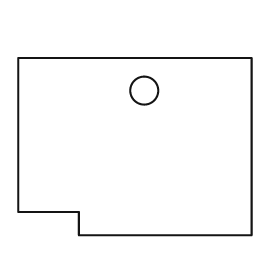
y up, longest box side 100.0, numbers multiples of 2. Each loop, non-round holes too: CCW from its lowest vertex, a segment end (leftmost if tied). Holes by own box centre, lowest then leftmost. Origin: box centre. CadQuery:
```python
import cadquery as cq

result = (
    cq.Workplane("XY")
    .moveTo(-24.0, -38.0)
    .lineTo(50.0, -38.0)
    .lineTo(50.0, 38.0)
    .lineTo(-50.0, 38.0)
    .lineTo(-50.0, -28.0)
    .lineTo(-24.0, -28.0)
    .close()
    .moveTo(4.0, 24.0)
    .circle(6.0)
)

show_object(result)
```